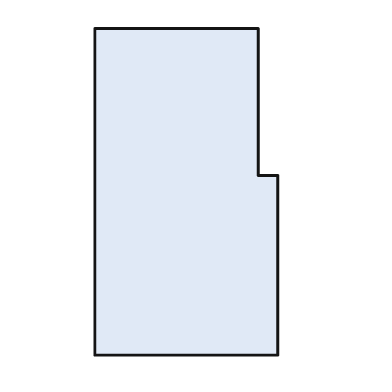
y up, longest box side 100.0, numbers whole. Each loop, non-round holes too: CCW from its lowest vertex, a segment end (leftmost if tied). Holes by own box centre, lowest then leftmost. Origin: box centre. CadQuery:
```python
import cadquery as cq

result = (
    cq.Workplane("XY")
    .moveTo(-28.0, -50.0)
    .lineTo(28.0, -50.0)
    .lineTo(28.0, 5.0)
    .lineTo(22.0, 5.0)
    .lineTo(22.0, 50.0)
    .lineTo(-28.0, 50.0)
    .close()
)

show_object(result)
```